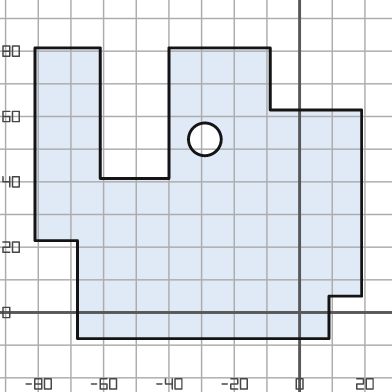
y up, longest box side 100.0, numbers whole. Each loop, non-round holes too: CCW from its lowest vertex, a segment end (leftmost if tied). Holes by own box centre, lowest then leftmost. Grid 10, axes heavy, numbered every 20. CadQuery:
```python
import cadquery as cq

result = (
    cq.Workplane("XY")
    .moveTo(-68.0, -8.0)
    .lineTo(9.0, -8.0)
    .lineTo(9.0, 5.0)
    .lineTo(19.0, 5.0)
    .lineTo(19.0, 62.0)
    .lineTo(-9.0, 62.0)
    .lineTo(-9.0, 81.0)
    .lineTo(-40.0, 81.0)
    .lineTo(-40.0, 41.0)
    .lineTo(-61.0, 41.0)
    .lineTo(-61.0, 81.0)
    .lineTo(-81.0, 81.0)
    .lineTo(-81.0, 22.0)
    .lineTo(-68.0, 22.0)
    .close()
    .moveTo(-29.0, 53.0)
    .circle(5.0)
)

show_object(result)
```